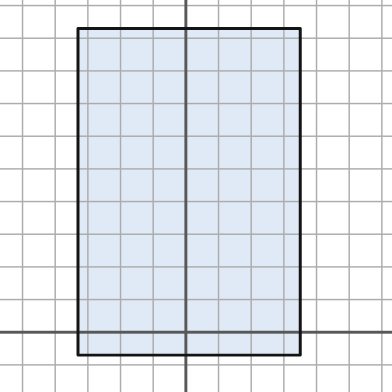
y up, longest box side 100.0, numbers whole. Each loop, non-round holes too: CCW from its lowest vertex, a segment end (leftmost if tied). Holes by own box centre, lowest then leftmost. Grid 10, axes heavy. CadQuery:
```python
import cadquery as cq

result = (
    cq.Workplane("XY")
    .moveTo(-33.0, -7.0)
    .lineTo(35.0, -7.0)
    .lineTo(35.0, 93.0)
    .lineTo(-33.0, 93.0)
    .close()
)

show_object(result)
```